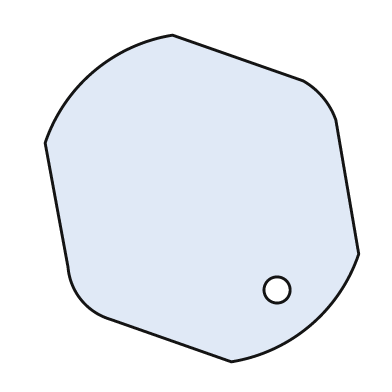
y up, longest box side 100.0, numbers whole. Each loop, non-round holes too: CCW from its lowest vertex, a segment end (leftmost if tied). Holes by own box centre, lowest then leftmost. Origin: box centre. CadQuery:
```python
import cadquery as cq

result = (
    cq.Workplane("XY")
    .moveTo(9.0, -50.0)
    .threePointArc((33.0, -39.0), (48.0, -17.0))
    .lineTo(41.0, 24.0)
    .threePointArc((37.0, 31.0), (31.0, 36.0))
    .lineTo(-9.0, 50.0)
    .threePointArc((-33.0, 39.0), (-48.0, 17.0))
    .lineTo(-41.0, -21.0)
    .threePointArc((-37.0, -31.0), (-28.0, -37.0))
    .close()
    .moveTo(23.0, -28.0)
    .circle(4.0)
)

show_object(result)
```